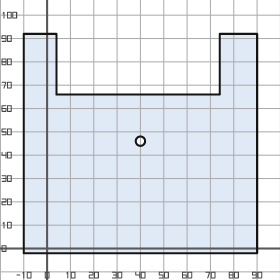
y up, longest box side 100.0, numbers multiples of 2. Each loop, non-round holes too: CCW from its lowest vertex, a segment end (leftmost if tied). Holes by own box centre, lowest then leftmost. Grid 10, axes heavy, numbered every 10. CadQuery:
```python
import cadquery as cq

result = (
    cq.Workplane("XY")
    .moveTo(-10.0, -2.0)
    .lineTo(90.0, -2.0)
    .lineTo(90.0, 92.0)
    .lineTo(74.0, 92.0)
    .lineTo(74.0, 66.0)
    .lineTo(4.0, 66.0)
    .lineTo(4.0, 92.0)
    .lineTo(-10.0, 92.0)
    .close()
    .moveTo(40.0, 46.0)
    .circle(2.0)
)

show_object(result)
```